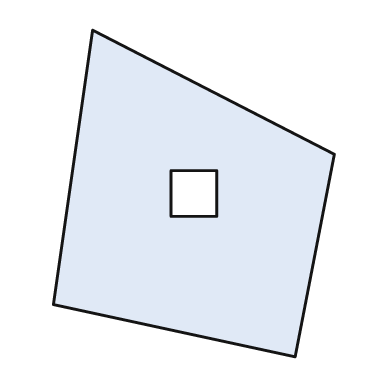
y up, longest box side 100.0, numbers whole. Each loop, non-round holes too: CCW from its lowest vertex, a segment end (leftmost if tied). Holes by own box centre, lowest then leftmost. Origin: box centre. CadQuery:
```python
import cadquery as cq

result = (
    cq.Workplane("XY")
    .moveTo(31.0, -50.0)
    .lineTo(43.0, 12.0)
    .lineTo(-31.0, 50.0)
    .lineTo(-43.0, -34.0)
    .close()
    .moveTo(-7.0, -7.0)
    .lineTo(7.0, -7.0)
    .lineTo(7.0, 7.0)
    .lineTo(-7.0, 7.0)
    .close()
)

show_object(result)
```